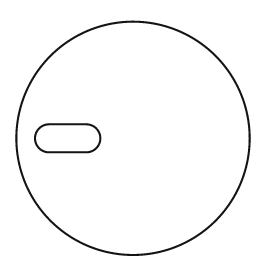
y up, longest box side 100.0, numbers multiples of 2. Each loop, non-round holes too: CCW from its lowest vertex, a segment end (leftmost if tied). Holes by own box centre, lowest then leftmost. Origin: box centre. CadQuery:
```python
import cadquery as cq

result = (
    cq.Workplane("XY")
    .moveTo(0.0, 0.0)
    .circle(50.0)
    .moveTo(-36.0, -6.0)
    .lineTo(-20.0, -6.0)
    .threePointArc((-14.0, 0.0), (-20.0, 6.0))
    .lineTo(-36.0, 6.0)
    .threePointArc((-42.0, 0.0), (-36.0, -6.0))
    .close()
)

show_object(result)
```